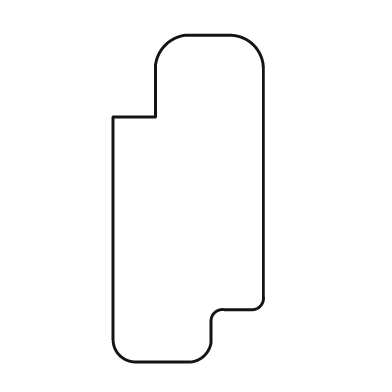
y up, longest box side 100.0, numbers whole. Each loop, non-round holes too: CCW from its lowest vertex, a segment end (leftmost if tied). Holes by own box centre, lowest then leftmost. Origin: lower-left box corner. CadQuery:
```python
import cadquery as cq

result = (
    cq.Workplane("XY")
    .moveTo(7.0, 0.0)
    .lineTo(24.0, 0.0)
    .threePointArc((28.0, 2.0), (30.0, 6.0))
    .lineTo(30.0, 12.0)
    .threePointArc((31.0, 15.0), (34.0, 16.0))
    .lineTo(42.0, 16.0)
    .threePointArc((45.0, 17.0), (46.0, 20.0))
    .lineTo(46.0, 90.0)
    .threePointArc((43.0, 97.0), (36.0, 100.0))
    .lineTo(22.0, 100.0)
    .threePointArc((16.0, 97.0), (13.0, 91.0))
    .lineTo(13.0, 75.0)
    .lineTo(0.0, 75.0)
    .lineTo(0.0, 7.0)
    .threePointArc((2.0, 2.0), (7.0, 0.0))
    .close()
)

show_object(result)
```